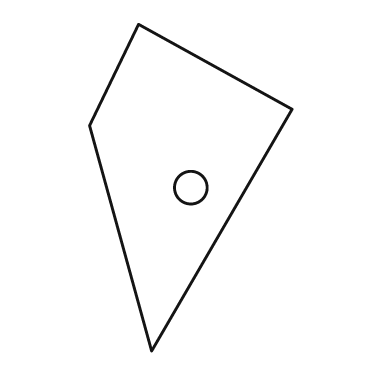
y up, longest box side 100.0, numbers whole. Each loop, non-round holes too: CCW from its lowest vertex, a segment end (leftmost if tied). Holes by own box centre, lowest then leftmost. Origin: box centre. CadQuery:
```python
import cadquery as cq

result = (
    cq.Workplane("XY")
    .moveTo(-12.0, -50.0)
    .lineTo(31.0, 24.0)
    .lineTo(-16.0, 50.0)
    .lineTo(-31.0, 19.0)
    .close()
    .moveTo(0.0, 0.0)
    .circle(5.0)
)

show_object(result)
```